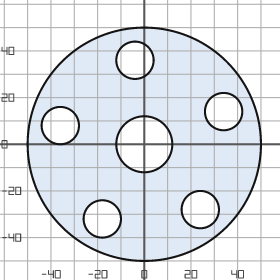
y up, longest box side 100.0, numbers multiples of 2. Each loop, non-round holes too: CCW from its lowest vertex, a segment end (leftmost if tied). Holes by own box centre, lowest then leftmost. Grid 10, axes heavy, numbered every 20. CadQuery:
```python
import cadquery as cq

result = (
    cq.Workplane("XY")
    .moveTo(0.0, 0.0)
    .circle(50.0)
    .moveTo(-18.0, -32.0)
    .circle(8.0)
    .moveTo(24.0, -28.0)
    .circle(8.0)
    .moveTo(0.0, 0.0)
    .circle(12.0)
    .moveTo(-36.0, 8.0)
    .circle(8.0)
    .moveTo(34.0, 14.0)
    .circle(8.0)
    .moveTo(-4.0, 36.0)
    .circle(8.0)
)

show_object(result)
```